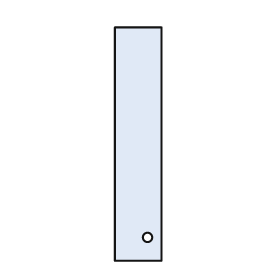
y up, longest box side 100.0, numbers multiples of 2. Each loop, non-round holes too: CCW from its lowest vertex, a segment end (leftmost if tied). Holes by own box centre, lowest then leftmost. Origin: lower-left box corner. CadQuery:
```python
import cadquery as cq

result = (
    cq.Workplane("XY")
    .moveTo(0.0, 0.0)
    .lineTo(20.0, 0.0)
    .lineTo(20.0, 100.0)
    .lineTo(0.0, 100.0)
    .close()
    .moveTo(14.0, 10.0)
    .circle(2.0)
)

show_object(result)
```